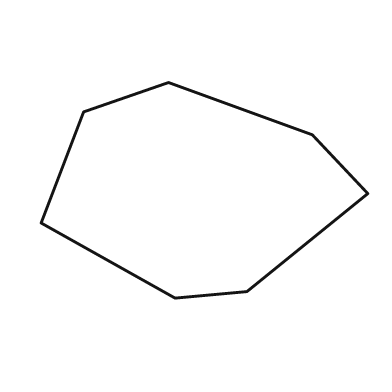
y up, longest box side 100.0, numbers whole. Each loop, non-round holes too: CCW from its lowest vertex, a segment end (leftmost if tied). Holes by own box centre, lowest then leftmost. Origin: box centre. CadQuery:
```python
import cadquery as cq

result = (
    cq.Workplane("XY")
    .moveTo(-9.0, -33.0)
    .lineTo(13.0, -31.0)
    .lineTo(50.0, -1.0)
    .lineTo(33.0, 17.0)
    .lineTo(-11.0, 33.0)
    .lineTo(-37.0, 24.0)
    .lineTo(-50.0, -10.0)
    .close()
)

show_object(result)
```